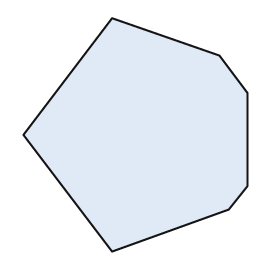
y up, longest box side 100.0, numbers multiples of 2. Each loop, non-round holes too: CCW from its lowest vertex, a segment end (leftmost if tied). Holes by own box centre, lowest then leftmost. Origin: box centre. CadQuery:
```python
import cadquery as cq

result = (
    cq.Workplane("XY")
    .moveTo(-10.0, -50.0)
    .lineTo(40.0, -32.0)
    .lineTo(48.0, -22.0)
    .lineTo(48.0, 18.0)
    .lineTo(36.0, 34.0)
    .lineTo(-10.0, 50.0)
    .lineTo(-48.0, 0.0)
    .close()
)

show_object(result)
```